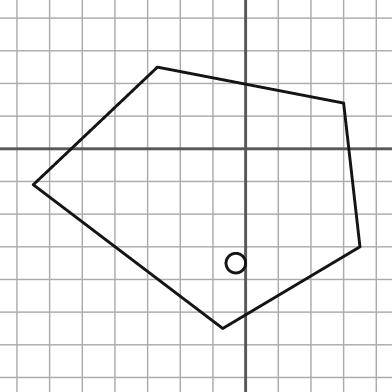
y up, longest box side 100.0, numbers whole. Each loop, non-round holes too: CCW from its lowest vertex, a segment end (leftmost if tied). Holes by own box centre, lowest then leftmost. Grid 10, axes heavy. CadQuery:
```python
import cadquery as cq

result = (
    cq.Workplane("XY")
    .moveTo(-7.0, -55.0)
    .lineTo(35.0, -30.0)
    .lineTo(30.0, 14.0)
    .lineTo(-27.0, 25.0)
    .lineTo(-65.0, -11.0)
    .close()
    .moveTo(-3.0, -35.0)
    .circle(3.0)
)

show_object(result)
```